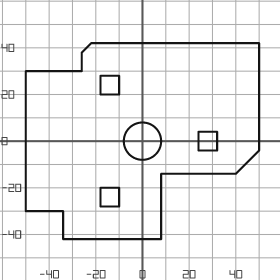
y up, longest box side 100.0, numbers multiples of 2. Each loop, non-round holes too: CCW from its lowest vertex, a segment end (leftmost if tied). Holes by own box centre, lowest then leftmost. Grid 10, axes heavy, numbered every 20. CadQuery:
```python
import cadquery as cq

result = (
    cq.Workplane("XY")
    .moveTo(-34.0, -42.0)
    .lineTo(8.0, -42.0)
    .lineTo(8.0, -14.0)
    .lineTo(40.0, -14.0)
    .lineTo(50.0, -4.0)
    .lineTo(50.0, 42.0)
    .lineTo(-22.0, 42.0)
    .lineTo(-26.0, 38.0)
    .lineTo(-26.0, 30.0)
    .lineTo(-50.0, 30.0)
    .lineTo(-50.0, -30.0)
    .lineTo(-34.0, -30.0)
    .close()
    .moveTo(-18.0, -28.0)
    .lineTo(-10.0, -28.0)
    .lineTo(-10.0, -20.0)
    .lineTo(-18.0, -20.0)
    .close()
    .moveTo(0.0, 0.0)
    .circle(8.0)
    .moveTo(24.0, -4.0)
    .lineTo(32.0, -4.0)
    .lineTo(32.0, 4.0)
    .lineTo(24.0, 4.0)
    .close()
    .moveTo(-18.0, 20.0)
    .lineTo(-10.0, 20.0)
    .lineTo(-10.0, 28.0)
    .lineTo(-18.0, 28.0)
    .close()
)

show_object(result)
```